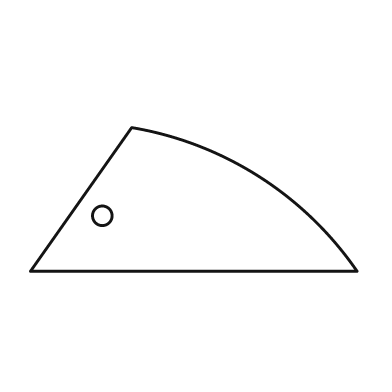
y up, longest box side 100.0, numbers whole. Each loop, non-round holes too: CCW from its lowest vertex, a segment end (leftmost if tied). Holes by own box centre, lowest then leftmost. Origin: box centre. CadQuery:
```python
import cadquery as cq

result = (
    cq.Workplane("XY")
    .moveTo(-50.0, -22.0)
    .lineTo(50.0, -22.0)
    .threePointArc((20.0, 7.0), (-19.0, 22.0))
    .close()
    .moveTo(-28.0, -5.0)
    .circle(3.0)
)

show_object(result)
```